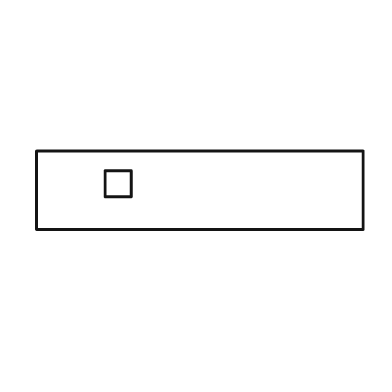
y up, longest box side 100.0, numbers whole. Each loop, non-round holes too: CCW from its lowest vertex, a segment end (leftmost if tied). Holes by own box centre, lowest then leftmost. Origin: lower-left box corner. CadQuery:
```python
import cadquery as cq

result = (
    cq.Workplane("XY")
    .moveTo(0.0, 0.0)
    .lineTo(100.0, 0.0)
    .lineTo(100.0, 24.0)
    .lineTo(0.0, 24.0)
    .close()
    .moveTo(21.0, 10.0)
    .lineTo(29.0, 10.0)
    .lineTo(29.0, 18.0)
    .lineTo(21.0, 18.0)
    .close()
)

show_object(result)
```